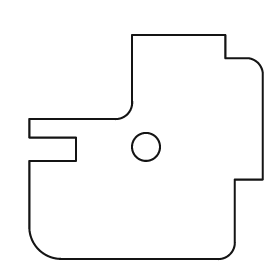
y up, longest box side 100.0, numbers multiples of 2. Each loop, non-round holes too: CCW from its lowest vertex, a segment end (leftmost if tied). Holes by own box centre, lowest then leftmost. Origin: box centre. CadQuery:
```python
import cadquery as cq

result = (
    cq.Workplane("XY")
    .moveTo(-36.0, -48.0)
    .lineTo(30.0, -48.0)
    .threePointArc((36.0, -46.0), (38.0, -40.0))
    .lineTo(38.0, -14.0)
    .lineTo(50.0, -14.0)
    .lineTo(50.0, 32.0)
    .threePointArc((48.0, 36.0), (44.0, 38.0))
    .lineTo(34.0, 38.0)
    .lineTo(34.0, 48.0)
    .lineTo(-6.0, 48.0)
    .lineTo(-6.0, 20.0)
    .threePointArc((-8.0, 14.0), (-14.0, 12.0))
    .lineTo(-50.0, 12.0)
    .lineTo(-50.0, 4.0)
    .lineTo(-30.0, 4.0)
    .lineTo(-30.0, -6.0)
    .lineTo(-50.0, -6.0)
    .lineTo(-50.0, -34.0)
    .threePointArc((-46.0, -44.0), (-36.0, -48.0))
    .close()
    .moveTo(0.0, 0.0)
    .circle(6.0)
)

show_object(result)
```